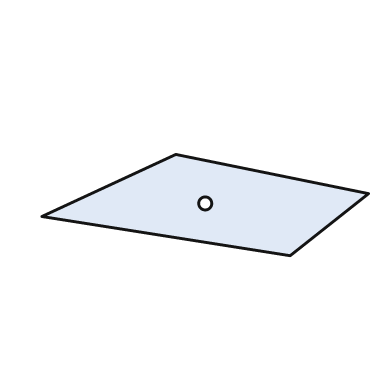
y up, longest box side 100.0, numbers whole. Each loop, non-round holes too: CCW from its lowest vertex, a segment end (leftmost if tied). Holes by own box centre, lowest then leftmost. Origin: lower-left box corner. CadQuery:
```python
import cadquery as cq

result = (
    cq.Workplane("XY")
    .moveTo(76.0, 0.0)
    .lineTo(100.0, 19.0)
    .lineTo(41.0, 31.0)
    .lineTo(0.0, 12.0)
    .close()
    .moveTo(50.0, 16.0)
    .circle(2.0)
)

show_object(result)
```